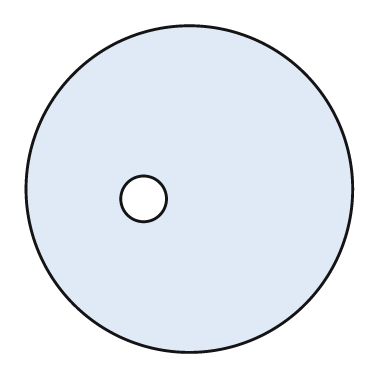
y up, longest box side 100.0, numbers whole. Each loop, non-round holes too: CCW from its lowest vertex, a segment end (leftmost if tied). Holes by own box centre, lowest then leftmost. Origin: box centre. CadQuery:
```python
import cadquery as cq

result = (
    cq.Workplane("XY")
    .moveTo(0.0, 0.0)
    .circle(50.0)
    .moveTo(-14.0, -3.0)
    .circle(7.0)
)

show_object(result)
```